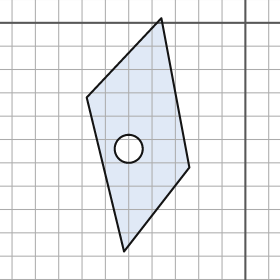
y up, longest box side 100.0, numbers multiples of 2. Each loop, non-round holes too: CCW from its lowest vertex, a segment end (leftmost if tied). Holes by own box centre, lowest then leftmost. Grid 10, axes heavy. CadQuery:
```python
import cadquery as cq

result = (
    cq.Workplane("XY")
    .moveTo(-52.0, -98.0)
    .lineTo(-24.0, -62.0)
    .lineTo(-36.0, 2.0)
    .lineTo(-68.0, -32.0)
    .close()
    .moveTo(-50.0, -54.0)
    .circle(6.0)
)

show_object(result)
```